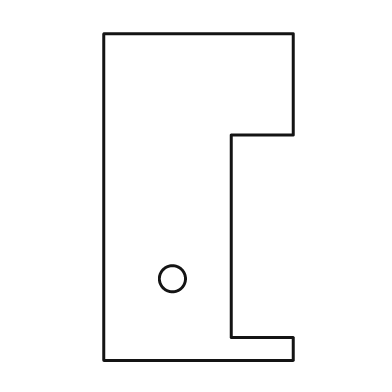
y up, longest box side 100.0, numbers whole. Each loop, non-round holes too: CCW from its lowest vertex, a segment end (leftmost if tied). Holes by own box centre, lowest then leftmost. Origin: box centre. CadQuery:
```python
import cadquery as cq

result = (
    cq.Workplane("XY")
    .moveTo(-29.0, -50.0)
    .lineTo(29.0, -50.0)
    .lineTo(29.0, -43.0)
    .lineTo(10.0, -43.0)
    .lineTo(10.0, 19.0)
    .lineTo(29.0, 19.0)
    .lineTo(29.0, 50.0)
    .lineTo(-29.0, 50.0)
    .close()
    .moveTo(-8.0, -25.0)
    .circle(4.0)
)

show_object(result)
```